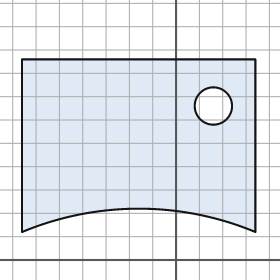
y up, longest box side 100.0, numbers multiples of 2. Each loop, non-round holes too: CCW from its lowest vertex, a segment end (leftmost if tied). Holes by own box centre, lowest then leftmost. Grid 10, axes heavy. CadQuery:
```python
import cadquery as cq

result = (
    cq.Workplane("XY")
    .moveTo(-66.0, 12.0)
    .threePointArc((-16.0, 22.0), (34.0, 12.0))
    .lineTo(34.0, 86.0)
    .lineTo(-66.0, 86.0)
    .close()
    .moveTo(16.0, 66.0)
    .circle(8.0)
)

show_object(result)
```